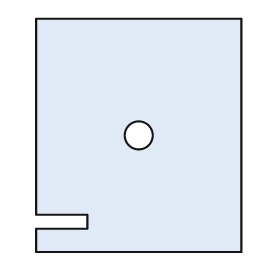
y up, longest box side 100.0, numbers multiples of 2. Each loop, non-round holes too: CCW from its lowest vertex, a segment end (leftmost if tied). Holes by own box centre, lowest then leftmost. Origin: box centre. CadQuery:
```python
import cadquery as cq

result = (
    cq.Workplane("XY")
    .moveTo(-44.0, -50.0)
    .lineTo(44.0, -50.0)
    .lineTo(44.0, 50.0)
    .lineTo(-44.0, 50.0)
    .lineTo(-44.0, -34.0)
    .lineTo(-22.0, -34.0)
    .lineTo(-22.0, -40.0)
    .lineTo(-44.0, -40.0)
    .close()
    .moveTo(0.0, 0.0)
    .circle(6.0)
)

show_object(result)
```